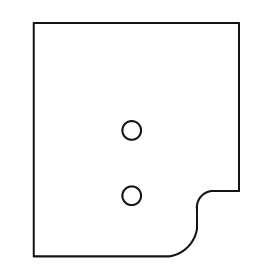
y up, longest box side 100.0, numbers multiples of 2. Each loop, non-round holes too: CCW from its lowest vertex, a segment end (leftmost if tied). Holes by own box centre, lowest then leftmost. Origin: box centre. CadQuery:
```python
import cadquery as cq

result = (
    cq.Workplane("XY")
    .moveTo(-44.0, -50.0)
    .lineTo(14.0, -50.0)
    .threePointArc((22.0, -46.0), (26.0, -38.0))
    .lineTo(26.0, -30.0)
    .threePointArc((28.0, -24.0), (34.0, -22.0))
    .lineTo(44.0, -22.0)
    .lineTo(44.0, 50.0)
    .lineTo(-44.0, 50.0)
    .close()
    .moveTo(-2.0, -24.0)
    .circle(4.0)
    .moveTo(-2.0, 4.0)
    .circle(4.0)
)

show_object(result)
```